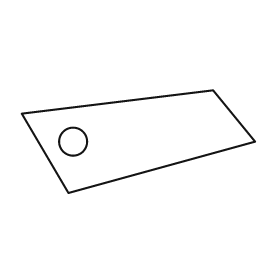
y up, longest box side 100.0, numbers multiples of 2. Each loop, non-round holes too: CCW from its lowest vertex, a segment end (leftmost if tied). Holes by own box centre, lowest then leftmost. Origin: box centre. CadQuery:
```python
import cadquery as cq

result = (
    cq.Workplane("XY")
    .moveTo(-30.0, -22.0)
    .lineTo(50.0, 0.0)
    .lineTo(32.0, 22.0)
    .lineTo(-50.0, 12.0)
    .close()
    .moveTo(-28.0, 0.0)
    .circle(6.0)
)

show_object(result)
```